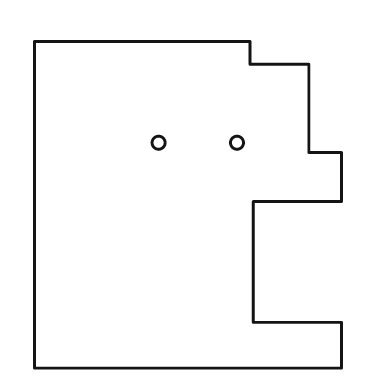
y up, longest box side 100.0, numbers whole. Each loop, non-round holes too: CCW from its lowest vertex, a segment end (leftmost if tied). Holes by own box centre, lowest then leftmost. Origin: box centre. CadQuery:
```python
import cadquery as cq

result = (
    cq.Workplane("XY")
    .moveTo(-47.0, -50.0)
    .lineTo(47.0, -50.0)
    .lineTo(47.0, -36.0)
    .lineTo(20.0, -36.0)
    .lineTo(20.0, 1.0)
    .lineTo(47.0, 1.0)
    .lineTo(47.0, 16.0)
    .lineTo(37.0, 16.0)
    .lineTo(37.0, 43.0)
    .lineTo(19.0, 43.0)
    .lineTo(19.0, 50.0)
    .lineTo(-47.0, 50.0)
    .close()
    .moveTo(-9.0, 19.0)
    .circle(2.0)
    .moveTo(15.0, 19.0)
    .circle(2.0)
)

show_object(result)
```